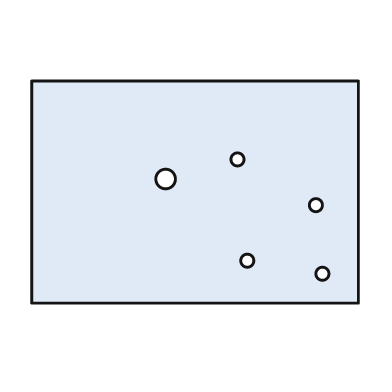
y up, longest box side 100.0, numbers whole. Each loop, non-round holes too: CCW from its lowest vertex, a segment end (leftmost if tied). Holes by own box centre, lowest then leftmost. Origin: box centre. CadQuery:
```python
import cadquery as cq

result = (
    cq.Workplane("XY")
    .moveTo(-50.0, -34.0)
    .lineTo(50.0, -34.0)
    .lineTo(50.0, 34.0)
    .lineTo(-50.0, 34.0)
    .close()
    .moveTo(39.0, -25.0)
    .circle(2.0)
    .moveTo(16.0, -21.0)
    .circle(2.0)
    .moveTo(37.0, -4.0)
    .circle(2.0)
    .moveTo(-9.0, 4.0)
    .circle(3.0)
    .moveTo(13.0, 10.0)
    .circle(2.0)
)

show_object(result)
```